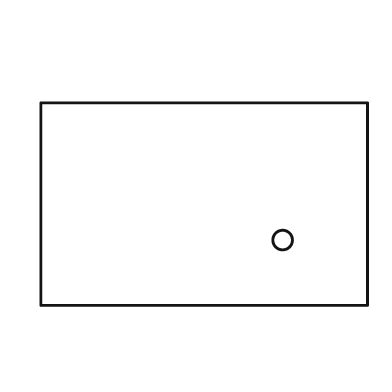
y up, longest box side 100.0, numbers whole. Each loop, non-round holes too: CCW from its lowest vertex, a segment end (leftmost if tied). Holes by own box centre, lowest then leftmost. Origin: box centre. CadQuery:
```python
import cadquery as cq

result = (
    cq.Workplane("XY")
    .moveTo(-50.0, -31.0)
    .lineTo(50.0, -31.0)
    .lineTo(50.0, 31.0)
    .lineTo(-50.0, 31.0)
    .close()
    .moveTo(24.0, -11.0)
    .circle(3.0)
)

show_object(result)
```